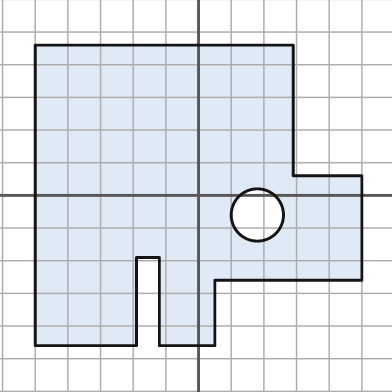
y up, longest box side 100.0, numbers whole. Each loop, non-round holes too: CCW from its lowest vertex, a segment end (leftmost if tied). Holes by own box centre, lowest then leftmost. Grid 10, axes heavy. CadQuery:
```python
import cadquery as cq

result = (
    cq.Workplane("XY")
    .moveTo(-50.0, -46.0)
    .lineTo(-19.0, -46.0)
    .lineTo(-19.0, -19.0)
    .lineTo(-12.0, -19.0)
    .lineTo(-12.0, -46.0)
    .lineTo(5.0, -46.0)
    .lineTo(5.0, -26.0)
    .lineTo(50.0, -26.0)
    .lineTo(50.0, 6.0)
    .lineTo(29.0, 6.0)
    .lineTo(29.0, 46.0)
    .lineTo(-50.0, 46.0)
    .close()
    .moveTo(18.0, -6.0)
    .circle(8.0)
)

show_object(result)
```